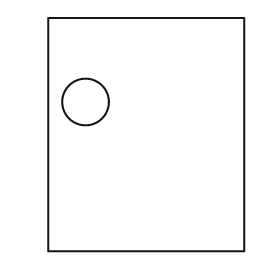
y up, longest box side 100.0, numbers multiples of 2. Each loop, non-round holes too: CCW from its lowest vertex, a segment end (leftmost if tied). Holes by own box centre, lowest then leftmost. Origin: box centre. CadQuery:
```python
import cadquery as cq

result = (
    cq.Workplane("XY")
    .moveTo(-42.0, -50.0)
    .lineTo(42.0, -50.0)
    .lineTo(42.0, 50.0)
    .lineTo(-42.0, 50.0)
    .close()
    .moveTo(-26.0, 14.0)
    .circle(10.0)
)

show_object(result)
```